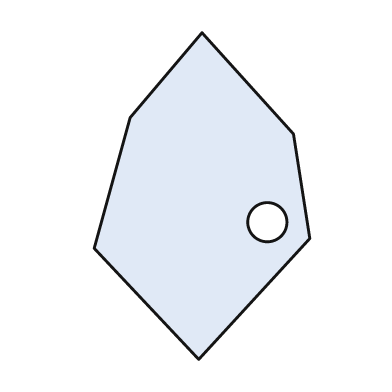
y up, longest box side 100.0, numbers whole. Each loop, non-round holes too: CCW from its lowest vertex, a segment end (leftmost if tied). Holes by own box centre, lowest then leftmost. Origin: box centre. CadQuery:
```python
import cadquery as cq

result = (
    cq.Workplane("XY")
    .moveTo(-1.0, -50.0)
    .lineTo(33.0, -13.0)
    .lineTo(28.0, 19.0)
    .lineTo(0.0, 50.0)
    .lineTo(-22.0, 24.0)
    .lineTo(-33.0, -16.0)
    .close()
    .moveTo(20.0, -8.0)
    .circle(6.0)
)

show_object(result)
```